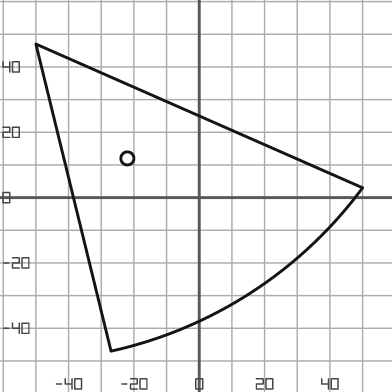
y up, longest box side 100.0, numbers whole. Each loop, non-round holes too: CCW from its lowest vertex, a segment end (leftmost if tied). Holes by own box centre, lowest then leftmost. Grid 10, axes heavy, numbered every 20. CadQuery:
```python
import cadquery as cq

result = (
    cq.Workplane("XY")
    .moveTo(-27.0, -47.0)
    .threePointArc((16.0, -29.0), (50.0, 3.0))
    .lineTo(-50.0, 47.0)
    .close()
    .moveTo(-22.0, 12.0)
    .circle(2.0)
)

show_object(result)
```